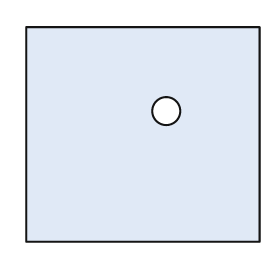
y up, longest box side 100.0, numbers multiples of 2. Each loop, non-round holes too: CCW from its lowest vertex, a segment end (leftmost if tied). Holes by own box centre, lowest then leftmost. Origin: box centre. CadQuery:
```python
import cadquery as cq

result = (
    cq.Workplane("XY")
    .moveTo(-50.0, -46.0)
    .lineTo(50.0, -46.0)
    .lineTo(50.0, 46.0)
    .lineTo(-50.0, 46.0)
    .close()
    .moveTo(10.0, 10.0)
    .circle(6.0)
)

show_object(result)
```